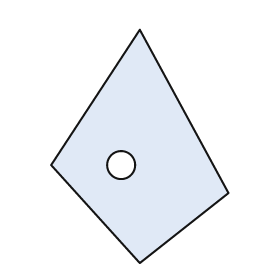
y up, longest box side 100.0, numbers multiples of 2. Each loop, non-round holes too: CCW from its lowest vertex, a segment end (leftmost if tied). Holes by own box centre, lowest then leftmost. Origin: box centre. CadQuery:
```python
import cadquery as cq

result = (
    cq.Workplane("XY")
    .moveTo(0.0, -50.0)
    .lineTo(38.0, -20.0)
    .lineTo(0.0, 50.0)
    .lineTo(-38.0, -8.0)
    .close()
    .moveTo(-8.0, -8.0)
    .circle(6.0)
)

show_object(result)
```